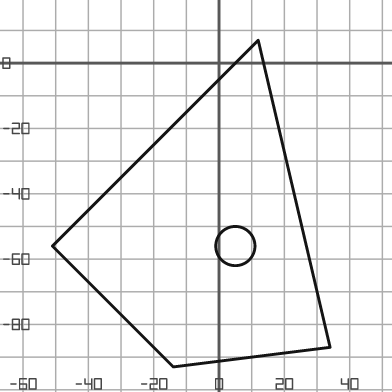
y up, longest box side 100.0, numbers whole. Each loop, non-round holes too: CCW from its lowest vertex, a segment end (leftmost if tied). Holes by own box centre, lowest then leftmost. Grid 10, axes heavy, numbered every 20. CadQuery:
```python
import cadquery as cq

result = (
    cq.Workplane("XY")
    .moveTo(-14.0, -93.0)
    .lineTo(34.0, -87.0)
    .lineTo(12.0, 7.0)
    .lineTo(-51.0, -56.0)
    .close()
    .moveTo(5.0, -56.0)
    .circle(6.0)
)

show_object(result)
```